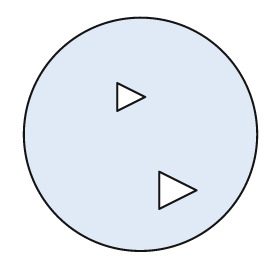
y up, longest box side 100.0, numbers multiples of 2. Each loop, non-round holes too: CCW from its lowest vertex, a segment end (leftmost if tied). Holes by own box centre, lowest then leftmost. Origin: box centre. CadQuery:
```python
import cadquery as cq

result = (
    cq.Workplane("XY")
    .moveTo(0.0, 0.0)
    .circle(50.0)
    .moveTo(8.0, -32.0)
    .lineTo(24.0, -24.0)
    .lineTo(8.0, -16.0)
    .close()
    .moveTo(-10.0, 10.0)
    .lineTo(2.0, 16.0)
    .lineTo(-10.0, 22.0)
    .close()
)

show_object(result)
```